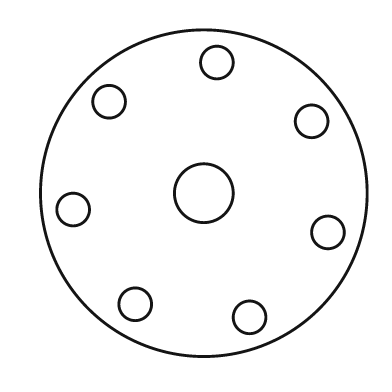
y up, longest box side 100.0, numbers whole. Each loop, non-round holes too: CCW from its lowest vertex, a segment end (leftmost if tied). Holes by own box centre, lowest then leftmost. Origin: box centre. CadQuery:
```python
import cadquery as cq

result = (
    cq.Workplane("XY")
    .moveTo(0.0, 0.0)
    .circle(50.0)
    .moveTo(14.0, -38.0)
    .circle(5.0)
    .moveTo(-21.0, -34.0)
    .circle(5.0)
    .moveTo(38.0, -12.0)
    .circle(5.0)
    .moveTo(-40.0, -5.0)
    .circle(5.0)
    .moveTo(0.0, 0.0)
    .circle(9.0)
    .moveTo(33.0, 22.0)
    .circle(5.0)
    .moveTo(-29.0, 28.0)
    .circle(5.0)
    .moveTo(4.0, 40.0)
    .circle(5.0)
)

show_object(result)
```